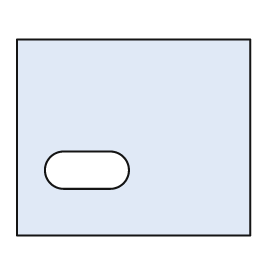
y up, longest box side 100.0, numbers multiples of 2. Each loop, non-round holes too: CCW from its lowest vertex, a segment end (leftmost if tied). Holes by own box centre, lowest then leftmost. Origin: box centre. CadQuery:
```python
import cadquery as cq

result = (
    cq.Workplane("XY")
    .moveTo(-50.0, -42.0)
    .lineTo(50.0, -42.0)
    .lineTo(50.0, 42.0)
    .lineTo(-50.0, 42.0)
    .close()
    .moveTo(-30.0, -22.0)
    .lineTo(-10.0, -22.0)
    .threePointArc((-2.0, -14.0), (-10.0, -6.0))
    .lineTo(-30.0, -6.0)
    .threePointArc((-38.0, -14.0), (-30.0, -22.0))
    .close()
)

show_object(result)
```